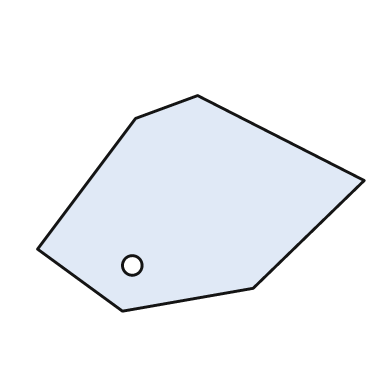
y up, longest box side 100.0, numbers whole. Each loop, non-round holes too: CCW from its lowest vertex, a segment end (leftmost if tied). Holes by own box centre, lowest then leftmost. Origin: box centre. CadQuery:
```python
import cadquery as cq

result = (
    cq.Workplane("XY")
    .moveTo(-24.0, -33.0)
    .lineTo(16.0, -26.0)
    .lineTo(50.0, 7.0)
    .lineTo(-1.0, 33.0)
    .lineTo(-20.0, 26.0)
    .lineTo(-50.0, -14.0)
    .close()
    .moveTo(-21.0, -19.0)
    .circle(3.0)
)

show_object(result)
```